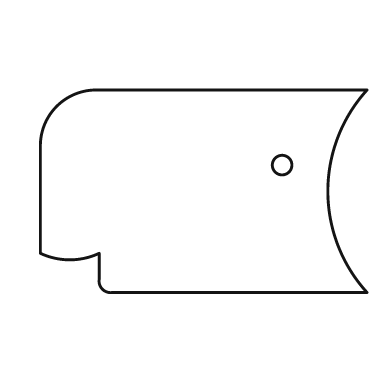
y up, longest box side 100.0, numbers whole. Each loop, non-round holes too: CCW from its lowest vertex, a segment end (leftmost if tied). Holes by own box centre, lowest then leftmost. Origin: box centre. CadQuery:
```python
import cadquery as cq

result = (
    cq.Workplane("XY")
    .moveTo(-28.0, -31.0)
    .lineTo(50.0, -31.0)
    .threePointArc((38.0, 0.0), (50.0, 31.0))
    .lineTo(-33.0, 31.0)
    .threePointArc((-45.0, 26.0), (-50.0, 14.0))
    .lineTo(-50.0, -19.0)
    .threePointArc((-41.0, -21.0), (-32.0, -19.0))
    .lineTo(-32.0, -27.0)
    .threePointArc((-31.0, -30.0), (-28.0, -31.0))
    .close()
    .moveTo(24.0, 8.0)
    .circle(3.0)
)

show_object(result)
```